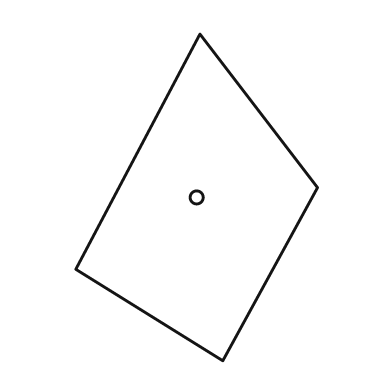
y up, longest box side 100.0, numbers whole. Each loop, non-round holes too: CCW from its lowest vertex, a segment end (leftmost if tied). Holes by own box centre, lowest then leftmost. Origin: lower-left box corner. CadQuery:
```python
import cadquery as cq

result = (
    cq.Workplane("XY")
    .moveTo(45.0, 0.0)
    .lineTo(74.0, 53.0)
    .lineTo(38.0, 100.0)
    .lineTo(0.0, 28.0)
    .close()
    .moveTo(37.0, 50.0)
    .circle(2.0)
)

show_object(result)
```